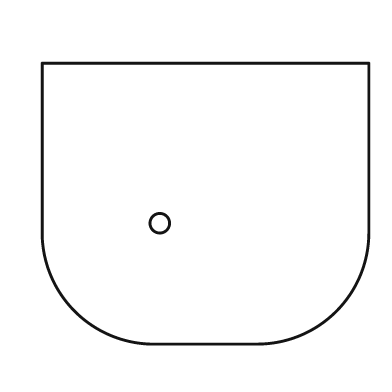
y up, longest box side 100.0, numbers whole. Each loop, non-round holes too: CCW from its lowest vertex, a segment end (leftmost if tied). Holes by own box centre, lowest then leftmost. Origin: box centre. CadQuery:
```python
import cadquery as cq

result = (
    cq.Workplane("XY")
    .moveTo(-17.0, -43.0)
    .lineTo(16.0, -43.0)
    .threePointArc((40.0, -33.0), (50.0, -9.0))
    .lineTo(50.0, 43.0)
    .lineTo(-50.0, 43.0)
    .lineTo(-50.0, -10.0)
    .threePointArc((-40.0, -33.0), (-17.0, -43.0))
    .close()
    .moveTo(-14.0, -6.0)
    .circle(3.0)
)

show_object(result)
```